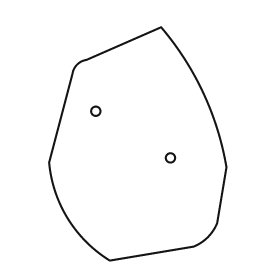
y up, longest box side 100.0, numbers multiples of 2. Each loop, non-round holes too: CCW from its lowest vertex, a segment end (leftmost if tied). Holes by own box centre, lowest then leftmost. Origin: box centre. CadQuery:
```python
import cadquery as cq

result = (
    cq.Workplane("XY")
    .moveTo(-12.0, -50.0)
    .lineTo(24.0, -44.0)
    .threePointArc((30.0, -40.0), (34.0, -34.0))
    .lineTo(38.0, -10.0)
    .threePointArc((28.0, 22.0), (10.0, 50.0))
    .lineTo(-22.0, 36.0)
    .threePointArc((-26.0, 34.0), (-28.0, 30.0))
    .lineTo(-38.0, -8.0)
    .threePointArc((-30.0, -32.0), (-12.0, -50.0))
    .close()
    .moveTo(14.0, -6.0)
    .circle(2.0)
    .moveTo(-18.0, 14.0)
    .circle(2.0)
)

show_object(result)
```